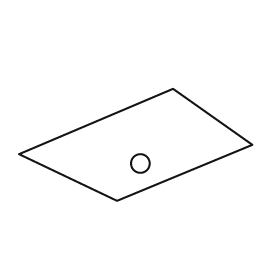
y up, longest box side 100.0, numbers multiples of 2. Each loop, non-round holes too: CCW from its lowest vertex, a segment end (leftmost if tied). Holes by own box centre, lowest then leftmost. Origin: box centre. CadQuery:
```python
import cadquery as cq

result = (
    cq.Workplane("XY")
    .moveTo(-8.0, -24.0)
    .lineTo(50.0, 0.0)
    .lineTo(16.0, 24.0)
    .lineTo(-50.0, -4.0)
    .close()
    .moveTo(2.0, -8.0)
    .circle(4.0)
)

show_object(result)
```